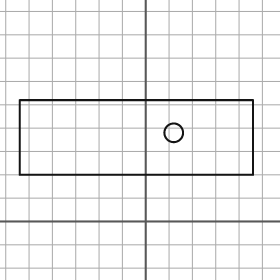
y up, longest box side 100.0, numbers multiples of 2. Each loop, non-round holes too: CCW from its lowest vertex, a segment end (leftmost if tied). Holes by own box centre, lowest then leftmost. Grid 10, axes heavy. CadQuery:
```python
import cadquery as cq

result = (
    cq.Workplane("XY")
    .moveTo(-54.0, 20.0)
    .lineTo(46.0, 20.0)
    .lineTo(46.0, 52.0)
    .lineTo(-54.0, 52.0)
    .close()
    .moveTo(12.0, 38.0)
    .circle(4.0)
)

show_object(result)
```